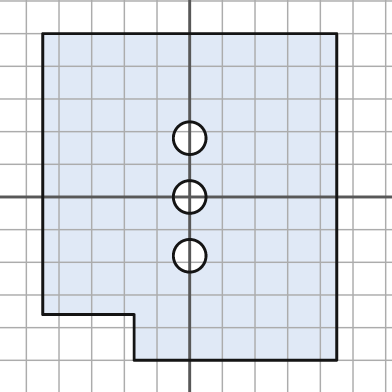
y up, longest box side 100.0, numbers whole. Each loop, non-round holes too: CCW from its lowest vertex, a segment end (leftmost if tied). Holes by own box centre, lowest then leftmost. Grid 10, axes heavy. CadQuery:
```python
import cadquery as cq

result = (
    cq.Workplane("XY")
    .moveTo(-17.0, -50.0)
    .lineTo(45.0, -50.0)
    .lineTo(45.0, 50.0)
    .lineTo(-45.0, 50.0)
    .lineTo(-45.0, -36.0)
    .lineTo(-17.0, -36.0)
    .close()
    .moveTo(0.0, -18.0)
    .circle(5.0)
    .moveTo(0.0, 0.0)
    .circle(5.0)
    .moveTo(0.0, 18.0)
    .circle(5.0)
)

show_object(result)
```